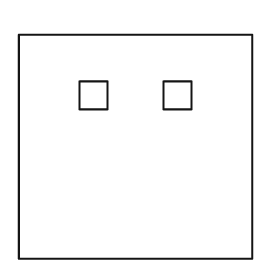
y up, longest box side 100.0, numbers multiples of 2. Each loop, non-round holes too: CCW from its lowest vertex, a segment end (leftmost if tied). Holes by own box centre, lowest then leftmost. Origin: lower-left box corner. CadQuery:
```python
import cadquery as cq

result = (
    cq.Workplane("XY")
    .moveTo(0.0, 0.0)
    .lineTo(100.0, 0.0)
    .lineTo(100.0, 96.0)
    .lineTo(0.0, 96.0)
    .close()
    .moveTo(26.0, 64.0)
    .lineTo(38.0, 64.0)
    .lineTo(38.0, 76.0)
    .lineTo(26.0, 76.0)
    .close()
    .moveTo(62.0, 64.0)
    .lineTo(74.0, 64.0)
    .lineTo(74.0, 76.0)
    .lineTo(62.0, 76.0)
    .close()
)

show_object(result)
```